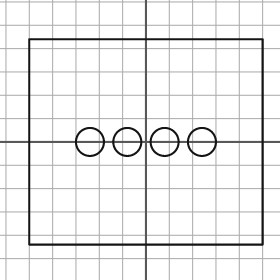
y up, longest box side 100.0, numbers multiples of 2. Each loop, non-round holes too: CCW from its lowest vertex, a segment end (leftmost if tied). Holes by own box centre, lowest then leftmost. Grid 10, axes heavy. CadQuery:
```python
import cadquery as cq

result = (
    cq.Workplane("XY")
    .moveTo(-50.0, -44.0)
    .lineTo(50.0, -44.0)
    .lineTo(50.0, 44.0)
    .lineTo(-50.0, 44.0)
    .close()
    .moveTo(-24.0, 0.0)
    .circle(6.0)
    .moveTo(-8.0, 0.0)
    .circle(6.0)
    .moveTo(8.0, 0.0)
    .circle(6.0)
    .moveTo(24.0, 0.0)
    .circle(6.0)
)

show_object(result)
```